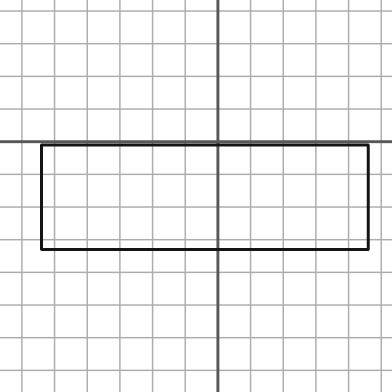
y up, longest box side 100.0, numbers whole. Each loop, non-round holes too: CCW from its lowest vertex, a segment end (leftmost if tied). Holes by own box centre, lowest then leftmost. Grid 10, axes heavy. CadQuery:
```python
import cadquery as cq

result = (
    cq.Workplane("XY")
    .moveTo(-54.0, -33.0)
    .lineTo(46.0, -33.0)
    .lineTo(46.0, -1.0)
    .lineTo(-54.0, -1.0)
    .close()
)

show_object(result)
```